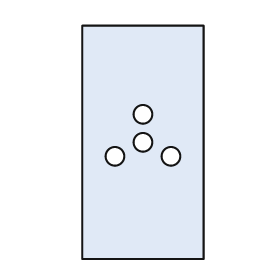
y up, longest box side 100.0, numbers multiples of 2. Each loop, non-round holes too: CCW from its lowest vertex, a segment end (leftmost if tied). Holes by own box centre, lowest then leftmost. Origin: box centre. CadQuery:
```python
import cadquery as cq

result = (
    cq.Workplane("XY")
    .moveTo(-26.0, -50.0)
    .lineTo(26.0, -50.0)
    .lineTo(26.0, 50.0)
    .lineTo(-26.0, 50.0)
    .close()
    .moveTo(-12.0, -6.0)
    .circle(4.0)
    .moveTo(12.0, -6.0)
    .circle(4.0)
    .moveTo(0.0, 0.0)
    .circle(4.0)
    .moveTo(0.0, 12.0)
    .circle(4.0)
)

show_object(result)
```